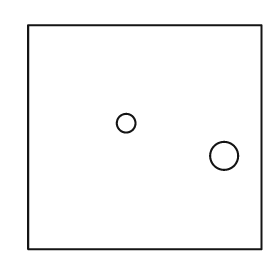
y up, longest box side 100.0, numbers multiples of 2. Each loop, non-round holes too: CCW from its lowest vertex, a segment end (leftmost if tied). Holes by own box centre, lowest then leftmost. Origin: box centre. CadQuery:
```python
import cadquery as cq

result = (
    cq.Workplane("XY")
    .moveTo(-50.0, -48.0)
    .lineTo(50.0, -48.0)
    .lineTo(50.0, 48.0)
    .lineTo(-50.0, 48.0)
    .close()
    .moveTo(34.0, -8.0)
    .circle(6.0)
    .moveTo(-8.0, 6.0)
    .circle(4.0)
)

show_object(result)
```